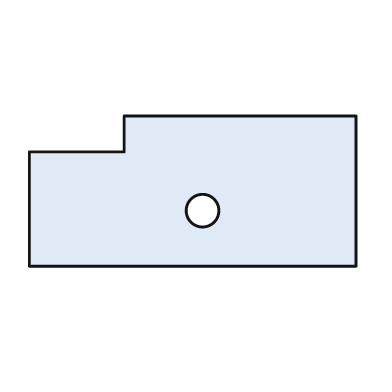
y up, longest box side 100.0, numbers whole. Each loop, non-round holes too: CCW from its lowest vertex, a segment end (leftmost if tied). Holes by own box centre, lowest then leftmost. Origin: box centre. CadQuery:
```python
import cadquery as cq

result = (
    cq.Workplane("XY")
    .moveTo(-50.0, -23.0)
    .lineTo(50.0, -23.0)
    .lineTo(50.0, 23.0)
    .lineTo(-21.0, 23.0)
    .lineTo(-21.0, 12.0)
    .lineTo(-50.0, 12.0)
    .close()
    .moveTo(3.0, -6.0)
    .circle(5.0)
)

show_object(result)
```